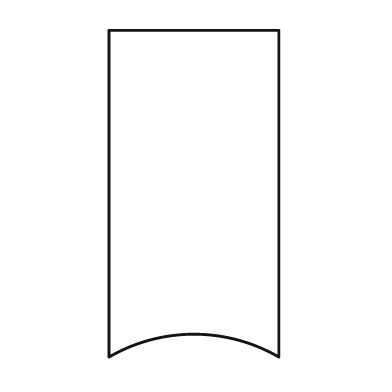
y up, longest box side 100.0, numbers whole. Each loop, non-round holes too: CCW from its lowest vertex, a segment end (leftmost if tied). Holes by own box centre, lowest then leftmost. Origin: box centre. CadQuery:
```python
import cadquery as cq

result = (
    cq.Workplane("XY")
    .moveTo(-26.0, -50.0)
    .threePointArc((0.0, -43.0), (26.0, -50.0))
    .lineTo(26.0, 50.0)
    .lineTo(-26.0, 50.0)
    .close()
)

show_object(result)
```